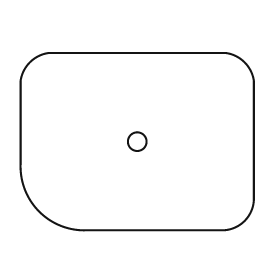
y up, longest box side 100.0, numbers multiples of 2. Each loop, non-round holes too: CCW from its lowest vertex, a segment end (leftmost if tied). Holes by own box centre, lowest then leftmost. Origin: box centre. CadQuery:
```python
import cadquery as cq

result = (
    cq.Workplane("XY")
    .moveTo(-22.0, -38.0)
    .lineTo(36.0, -38.0)
    .threePointArc((46.0, -34.0), (50.0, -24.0))
    .lineTo(50.0, 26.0)
    .threePointArc((46.0, 34.0), (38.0, 38.0))
    .lineTo(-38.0, 38.0)
    .threePointArc((-46.0, 34.0), (-50.0, 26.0))
    .lineTo(-50.0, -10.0)
    .threePointArc((-42.0, -30.0), (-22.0, -38.0))
    .close()
    .moveTo(0.0, 0.0)
    .circle(4.0)
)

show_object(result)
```